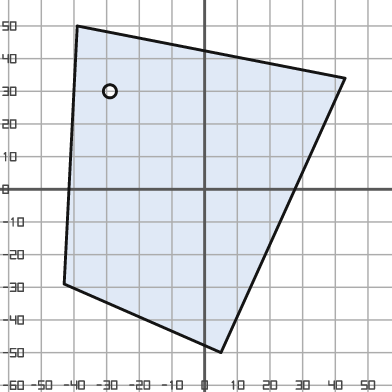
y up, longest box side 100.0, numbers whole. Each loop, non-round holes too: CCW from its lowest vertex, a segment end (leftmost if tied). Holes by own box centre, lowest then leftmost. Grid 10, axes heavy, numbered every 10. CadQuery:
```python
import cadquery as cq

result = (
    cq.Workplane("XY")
    .moveTo(5.0, -50.0)
    .lineTo(43.0, 34.0)
    .lineTo(-39.0, 50.0)
    .lineTo(-43.0, -29.0)
    .close()
    .moveTo(-29.0, 30.0)
    .circle(2.0)
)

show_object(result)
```